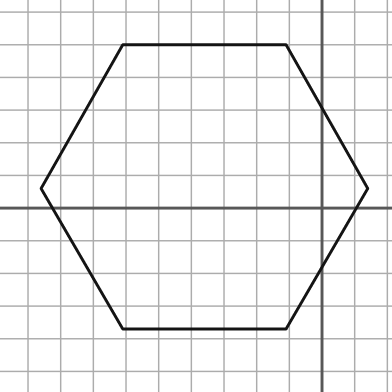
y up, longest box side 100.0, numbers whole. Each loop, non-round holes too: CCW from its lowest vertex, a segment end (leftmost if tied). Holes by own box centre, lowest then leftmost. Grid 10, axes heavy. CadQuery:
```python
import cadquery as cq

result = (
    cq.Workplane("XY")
    .moveTo(-61.0, -37.0)
    .lineTo(-11.0, -37.0)
    .lineTo(14.0, 6.0)
    .lineTo(-11.0, 50.0)
    .lineTo(-61.0, 50.0)
    .lineTo(-86.0, 6.0)
    .close()
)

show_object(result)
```